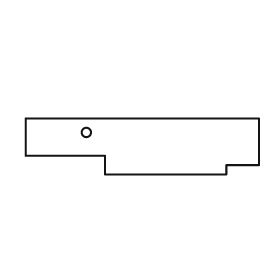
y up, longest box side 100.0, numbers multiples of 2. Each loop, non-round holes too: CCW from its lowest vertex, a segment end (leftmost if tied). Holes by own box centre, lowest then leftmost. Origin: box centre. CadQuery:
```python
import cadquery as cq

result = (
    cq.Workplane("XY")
    .moveTo(-16.0, -12.0)
    .lineTo(36.0, -12.0)
    .lineTo(36.0, -8.0)
    .lineTo(50.0, -8.0)
    .lineTo(50.0, 12.0)
    .lineTo(-50.0, 12.0)
    .lineTo(-50.0, -4.0)
    .lineTo(-16.0, -4.0)
    .close()
    .moveTo(-24.0, 6.0)
    .circle(2.0)
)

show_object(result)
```